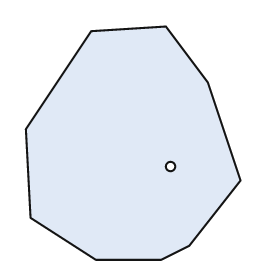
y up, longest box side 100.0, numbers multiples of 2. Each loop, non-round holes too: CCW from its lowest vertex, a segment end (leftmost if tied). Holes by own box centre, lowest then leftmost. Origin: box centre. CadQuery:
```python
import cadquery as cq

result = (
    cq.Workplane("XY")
    .moveTo(-16.0, -50.0)
    .lineTo(12.0, -50.0)
    .lineTo(24.0, -44.0)
    .lineTo(46.0, -16.0)
    .lineTo(32.0, 26.0)
    .lineTo(14.0, 50.0)
    .lineTo(-18.0, 48.0)
    .lineTo(-46.0, 6.0)
    .lineTo(-44.0, -32.0)
    .close()
    .moveTo(16.0, -10.0)
    .circle(2.0)
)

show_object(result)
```